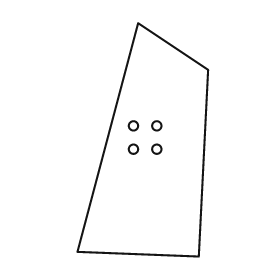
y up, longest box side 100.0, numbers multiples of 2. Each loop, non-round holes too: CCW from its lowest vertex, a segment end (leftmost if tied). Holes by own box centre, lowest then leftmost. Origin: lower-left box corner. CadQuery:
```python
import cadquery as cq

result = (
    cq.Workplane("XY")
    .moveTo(52.0, 0.0)
    .lineTo(56.0, 80.0)
    .lineTo(26.0, 100.0)
    .lineTo(0.0, 2.0)
    .close()
    .moveTo(24.0, 46.0)
    .circle(2.0)
    .moveTo(34.0, 46.0)
    .circle(2.0)
    .moveTo(24.0, 56.0)
    .circle(2.0)
    .moveTo(34.0, 56.0)
    .circle(2.0)
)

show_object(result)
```